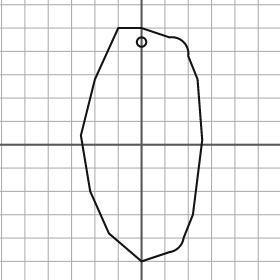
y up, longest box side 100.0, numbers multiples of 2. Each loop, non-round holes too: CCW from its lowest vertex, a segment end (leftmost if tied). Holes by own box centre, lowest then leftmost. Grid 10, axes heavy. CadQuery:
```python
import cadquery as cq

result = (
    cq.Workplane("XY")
    .moveTo(0.0, -50.0)
    .lineTo(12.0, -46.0)
    .threePointArc((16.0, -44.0), (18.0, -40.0))
    .lineTo(22.0, -30.0)
    .lineTo(26.0, 2.0)
    .lineTo(24.0, 28.0)
    .lineTo(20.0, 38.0)
    .threePointArc((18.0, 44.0), (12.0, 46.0))
    .lineTo(0.0, 50.0)
    .lineTo(-10.0, 50.0)
    .lineTo(-20.0, 28.0)
    .lineTo(-26.0, 4.0)
    .lineTo(-22.0, -20.0)
    .lineTo(-14.0, -38.0)
    .close()
    .moveTo(0.0, 44.0)
    .circle(2.0)
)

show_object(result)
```